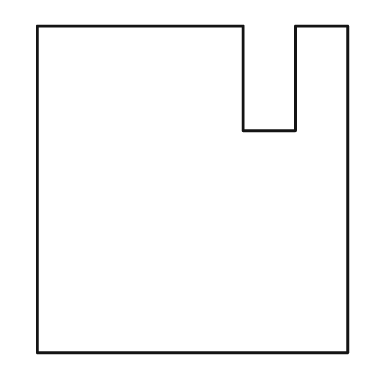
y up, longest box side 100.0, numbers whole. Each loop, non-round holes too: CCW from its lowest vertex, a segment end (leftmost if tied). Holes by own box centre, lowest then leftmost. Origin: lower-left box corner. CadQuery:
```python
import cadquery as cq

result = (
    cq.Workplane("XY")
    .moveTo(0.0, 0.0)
    .lineTo(95.0, 0.0)
    .lineTo(95.0, 100.0)
    .lineTo(79.0, 100.0)
    .lineTo(79.0, 68.0)
    .lineTo(63.0, 68.0)
    .lineTo(63.0, 100.0)
    .lineTo(0.0, 100.0)
    .close()
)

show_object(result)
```